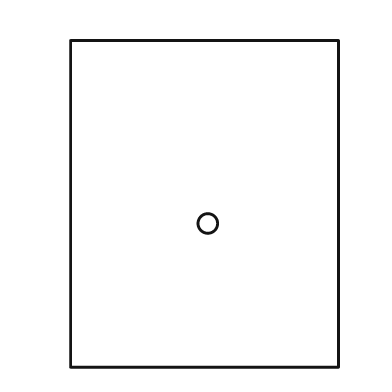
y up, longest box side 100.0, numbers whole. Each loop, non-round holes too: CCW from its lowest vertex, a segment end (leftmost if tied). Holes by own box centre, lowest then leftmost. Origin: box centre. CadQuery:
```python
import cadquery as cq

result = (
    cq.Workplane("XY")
    .moveTo(-41.0, -50.0)
    .lineTo(41.0, -50.0)
    .lineTo(41.0, 50.0)
    .lineTo(-41.0, 50.0)
    .close()
    .moveTo(1.0, -6.0)
    .circle(3.0)
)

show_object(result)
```